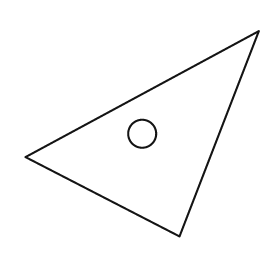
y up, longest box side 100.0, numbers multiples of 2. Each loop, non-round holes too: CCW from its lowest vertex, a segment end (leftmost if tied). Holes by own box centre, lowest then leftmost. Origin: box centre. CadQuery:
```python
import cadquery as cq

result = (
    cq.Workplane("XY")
    .moveTo(16.0, -44.0)
    .lineTo(50.0, 44.0)
    .lineTo(-50.0, -10.0)
    .close()
    .moveTo(0.0, 0.0)
    .circle(6.0)
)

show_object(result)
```